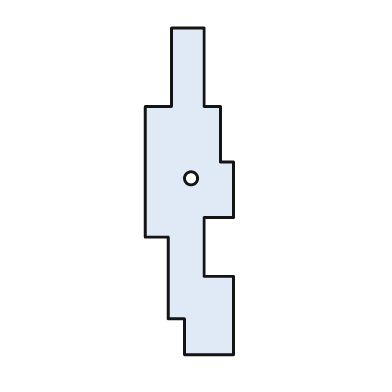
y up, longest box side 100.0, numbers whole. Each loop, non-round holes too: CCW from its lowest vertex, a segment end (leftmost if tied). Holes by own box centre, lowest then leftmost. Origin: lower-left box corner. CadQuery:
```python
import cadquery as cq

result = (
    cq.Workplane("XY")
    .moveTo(12.0, 0.0)
    .lineTo(27.0, 0.0)
    .lineTo(27.0, 24.0)
    .lineTo(18.0, 24.0)
    .lineTo(18.0, 42.0)
    .lineTo(27.0, 42.0)
    .lineTo(27.0, 59.0)
    .lineTo(23.0, 59.0)
    .lineTo(23.0, 76.0)
    .lineTo(18.0, 76.0)
    .lineTo(18.0, 100.0)
    .lineTo(8.0, 100.0)
    .lineTo(8.0, 76.0)
    .lineTo(0.0, 76.0)
    .lineTo(0.0, 36.0)
    .lineTo(7.0, 36.0)
    .lineTo(7.0, 11.0)
    .lineTo(12.0, 11.0)
    .close()
    .moveTo(14.0, 54.0)
    .circle(2.0)
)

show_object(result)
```